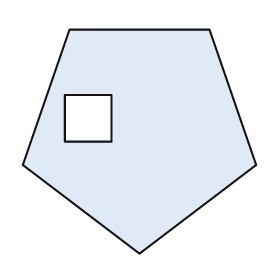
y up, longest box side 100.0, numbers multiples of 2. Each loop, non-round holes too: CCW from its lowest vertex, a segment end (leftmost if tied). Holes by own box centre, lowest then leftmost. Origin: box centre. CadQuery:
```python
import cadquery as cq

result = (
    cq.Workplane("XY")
    .moveTo(0.0, -48.0)
    .lineTo(50.0, -10.0)
    .lineTo(30.0, 48.0)
    .lineTo(-30.0, 48.0)
    .lineTo(-50.0, -10.0)
    .close()
    .moveTo(-32.0, 0.0)
    .lineTo(-12.0, 0.0)
    .lineTo(-12.0, 20.0)
    .lineTo(-32.0, 20.0)
    .close()
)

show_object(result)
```